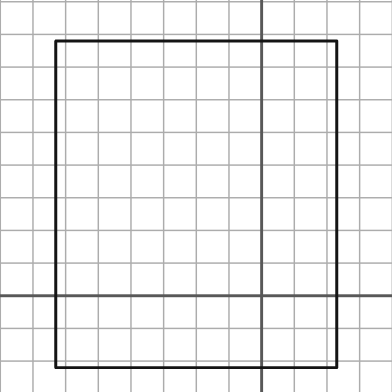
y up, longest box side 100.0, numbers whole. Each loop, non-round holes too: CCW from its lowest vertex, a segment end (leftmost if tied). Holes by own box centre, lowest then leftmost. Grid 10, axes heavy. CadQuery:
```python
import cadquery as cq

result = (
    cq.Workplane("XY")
    .moveTo(-63.0, -22.0)
    .lineTo(23.0, -22.0)
    .lineTo(23.0, 78.0)
    .lineTo(-63.0, 78.0)
    .close()
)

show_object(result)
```